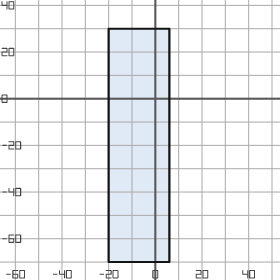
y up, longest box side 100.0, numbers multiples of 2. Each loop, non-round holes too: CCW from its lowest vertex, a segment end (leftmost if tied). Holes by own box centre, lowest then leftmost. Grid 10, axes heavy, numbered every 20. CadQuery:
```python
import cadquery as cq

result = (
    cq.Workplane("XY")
    .moveTo(-20.0, -70.0)
    .lineTo(6.0, -70.0)
    .lineTo(6.0, 30.0)
    .lineTo(-20.0, 30.0)
    .close()
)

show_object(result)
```